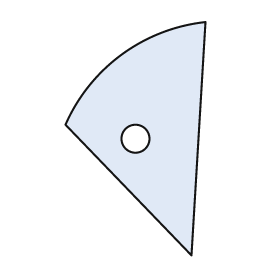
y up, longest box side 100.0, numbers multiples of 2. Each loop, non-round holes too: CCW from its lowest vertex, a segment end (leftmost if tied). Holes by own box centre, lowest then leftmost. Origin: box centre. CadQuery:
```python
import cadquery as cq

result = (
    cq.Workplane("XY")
    .moveTo(24.0, -50.0)
    .lineTo(30.0, 50.0)
    .threePointArc((-6.0, 36.0), (-30.0, 6.0))
    .close()
    .moveTo(0.0, 0.0)
    .circle(6.0)
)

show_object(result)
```